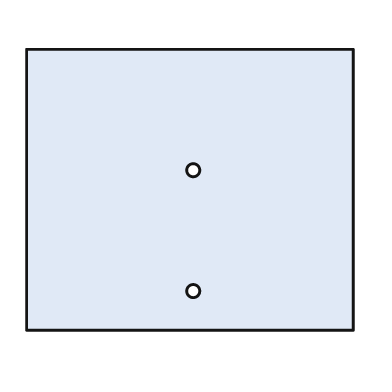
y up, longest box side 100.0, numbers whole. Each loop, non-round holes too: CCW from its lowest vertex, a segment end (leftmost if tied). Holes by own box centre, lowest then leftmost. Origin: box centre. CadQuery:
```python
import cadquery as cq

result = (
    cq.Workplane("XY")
    .moveTo(-50.0, -43.0)
    .lineTo(50.0, -43.0)
    .lineTo(50.0, 43.0)
    .lineTo(-50.0, 43.0)
    .close()
    .moveTo(1.0, -31.0)
    .circle(2.0)
    .moveTo(1.0, 6.0)
    .circle(2.0)
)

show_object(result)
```